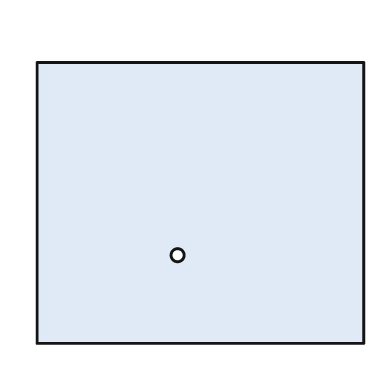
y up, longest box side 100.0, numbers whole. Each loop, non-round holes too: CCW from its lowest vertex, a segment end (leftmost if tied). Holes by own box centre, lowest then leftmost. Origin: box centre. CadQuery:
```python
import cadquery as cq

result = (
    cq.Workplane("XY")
    .moveTo(-50.0, -43.0)
    .lineTo(50.0, -43.0)
    .lineTo(50.0, 43.0)
    .lineTo(-50.0, 43.0)
    .close()
    .moveTo(-7.0, -16.0)
    .circle(2.0)
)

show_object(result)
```